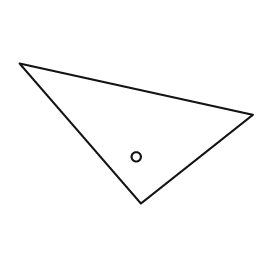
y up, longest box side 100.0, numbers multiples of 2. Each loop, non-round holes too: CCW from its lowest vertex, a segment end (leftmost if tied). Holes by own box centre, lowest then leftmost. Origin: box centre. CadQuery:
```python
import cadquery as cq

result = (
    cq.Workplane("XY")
    .moveTo(2.0, -30.0)
    .lineTo(50.0, 8.0)
    .lineTo(-50.0, 30.0)
    .close()
    .moveTo(0.0, -10.0)
    .circle(2.0)
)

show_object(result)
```